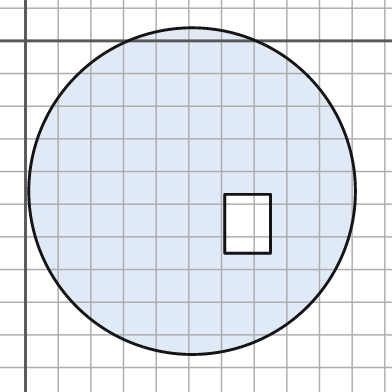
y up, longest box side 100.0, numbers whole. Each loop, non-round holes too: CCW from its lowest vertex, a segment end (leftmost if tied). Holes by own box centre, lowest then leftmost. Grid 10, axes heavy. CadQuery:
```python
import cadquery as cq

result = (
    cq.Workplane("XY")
    .moveTo(51.0, -46.0)
    .circle(50.0)
    .moveTo(61.0, -65.0)
    .lineTo(75.0, -65.0)
    .lineTo(75.0, -47.0)
    .lineTo(61.0, -47.0)
    .close()
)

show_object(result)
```